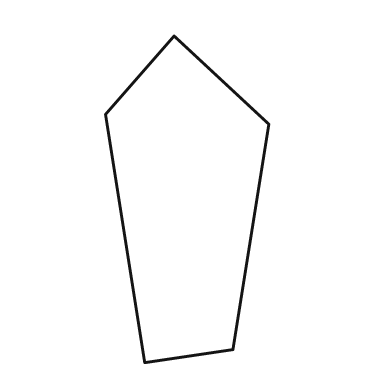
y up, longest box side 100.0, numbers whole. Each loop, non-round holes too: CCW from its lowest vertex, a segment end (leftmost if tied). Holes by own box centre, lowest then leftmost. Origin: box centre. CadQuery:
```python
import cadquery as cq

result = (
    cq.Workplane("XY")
    .moveTo(-13.0, -50.0)
    .lineTo(14.0, -46.0)
    .lineTo(25.0, 23.0)
    .lineTo(-4.0, 50.0)
    .lineTo(-25.0, 26.0)
    .close()
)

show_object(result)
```